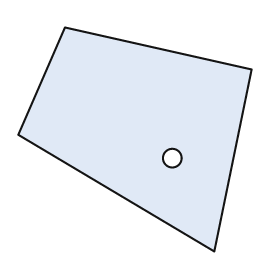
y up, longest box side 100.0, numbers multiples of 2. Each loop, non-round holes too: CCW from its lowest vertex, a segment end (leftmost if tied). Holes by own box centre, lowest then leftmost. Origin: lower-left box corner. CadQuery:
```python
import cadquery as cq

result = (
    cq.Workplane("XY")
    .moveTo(84.0, 0.0)
    .lineTo(100.0, 78.0)
    .lineTo(20.0, 96.0)
    .lineTo(0.0, 50.0)
    .close()
    .moveTo(66.0, 40.0)
    .circle(4.0)
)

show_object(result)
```